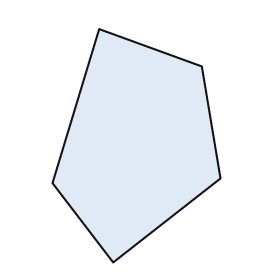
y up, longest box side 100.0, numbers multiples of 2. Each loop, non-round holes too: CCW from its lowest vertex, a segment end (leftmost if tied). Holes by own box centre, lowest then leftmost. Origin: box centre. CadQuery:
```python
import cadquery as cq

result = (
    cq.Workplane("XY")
    .moveTo(-10.0, -50.0)
    .lineTo(36.0, -14.0)
    .lineTo(28.0, 34.0)
    .lineTo(-16.0, 50.0)
    .lineTo(-36.0, -16.0)
    .close()
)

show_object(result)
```